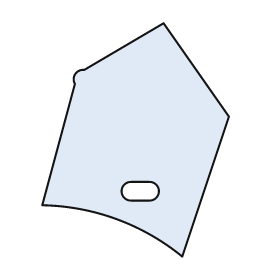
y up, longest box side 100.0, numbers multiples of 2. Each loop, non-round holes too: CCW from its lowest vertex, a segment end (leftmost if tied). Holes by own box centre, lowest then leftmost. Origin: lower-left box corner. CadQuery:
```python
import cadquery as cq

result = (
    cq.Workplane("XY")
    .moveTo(60.0, 0.0)
    .lineTo(80.0, 60.0)
    .lineTo(52.0, 100.0)
    .lineTo(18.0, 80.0)
    .threePointArc((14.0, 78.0), (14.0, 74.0))
    .lineTo(0.0, 22.0)
    .threePointArc((32.0, 16.0), (60.0, 0.0))
    .close()
    .moveTo(38.0, 24.0)
    .lineTo(46.0, 24.0)
    .threePointArc((50.0, 28.0), (46.0, 32.0))
    .lineTo(38.0, 32.0)
    .threePointArc((34.0, 28.0), (38.0, 24.0))
    .close()
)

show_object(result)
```